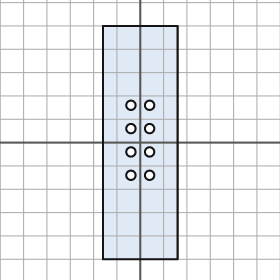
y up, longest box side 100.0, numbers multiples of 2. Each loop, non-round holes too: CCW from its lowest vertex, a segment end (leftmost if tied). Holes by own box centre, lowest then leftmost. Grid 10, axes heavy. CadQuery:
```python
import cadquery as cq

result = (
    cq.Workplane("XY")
    .moveTo(-16.0, -50.0)
    .lineTo(16.0, -50.0)
    .lineTo(16.0, 50.0)
    .lineTo(-16.0, 50.0)
    .close()
    .moveTo(-4.0, -14.0)
    .circle(2.0)
    .moveTo(4.0, -14.0)
    .circle(2.0)
    .moveTo(-4.0, -4.0)
    .circle(2.0)
    .moveTo(4.0, -4.0)
    .circle(2.0)
    .moveTo(-4.0, 6.0)
    .circle(2.0)
    .moveTo(4.0, 6.0)
    .circle(2.0)
    .moveTo(-4.0, 16.0)
    .circle(2.0)
    .moveTo(4.0, 16.0)
    .circle(2.0)
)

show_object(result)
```